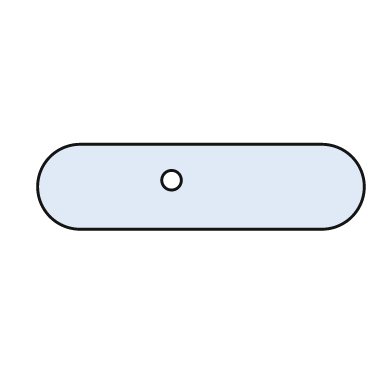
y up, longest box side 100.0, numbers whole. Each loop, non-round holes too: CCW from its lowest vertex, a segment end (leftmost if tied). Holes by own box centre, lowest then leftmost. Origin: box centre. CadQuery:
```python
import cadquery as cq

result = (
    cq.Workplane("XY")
    .moveTo(-37.0, -13.0)
    .lineTo(37.0, -13.0)
    .threePointArc((50.0, 0.0), (37.0, 13.0))
    .lineTo(-37.0, 13.0)
    .threePointArc((-50.0, 0.0), (-37.0, -13.0))
    .close()
    .moveTo(-9.0, 2.0)
    .circle(3.0)
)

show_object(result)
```